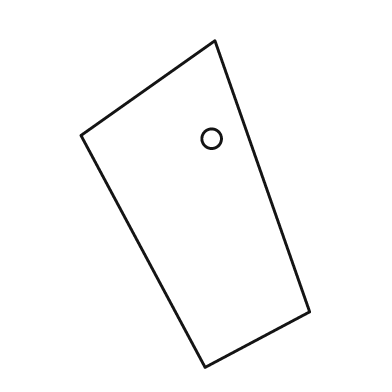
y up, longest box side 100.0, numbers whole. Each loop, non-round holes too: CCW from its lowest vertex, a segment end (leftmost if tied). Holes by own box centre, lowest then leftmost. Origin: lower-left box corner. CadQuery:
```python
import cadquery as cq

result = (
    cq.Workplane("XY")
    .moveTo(38.0, 0.0)
    .lineTo(70.0, 17.0)
    .lineTo(41.0, 100.0)
    .lineTo(0.0, 71.0)
    .close()
    .moveTo(40.0, 70.0)
    .circle(3.0)
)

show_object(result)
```